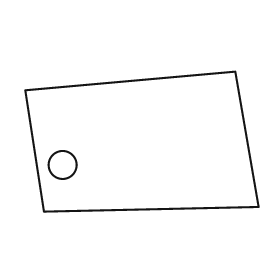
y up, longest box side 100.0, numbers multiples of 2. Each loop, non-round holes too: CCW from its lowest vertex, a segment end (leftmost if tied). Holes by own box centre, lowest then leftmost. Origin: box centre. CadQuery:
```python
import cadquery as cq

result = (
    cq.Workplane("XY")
    .moveTo(-42.0, -30.0)
    .lineTo(50.0, -28.0)
    .lineTo(40.0, 30.0)
    .lineTo(-50.0, 22.0)
    .close()
    .moveTo(-34.0, -10.0)
    .circle(6.0)
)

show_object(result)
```